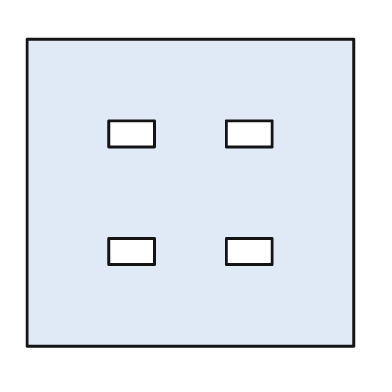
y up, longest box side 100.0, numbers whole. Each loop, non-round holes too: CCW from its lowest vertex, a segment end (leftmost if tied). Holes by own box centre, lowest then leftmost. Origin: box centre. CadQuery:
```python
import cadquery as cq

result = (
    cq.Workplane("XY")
    .moveTo(-50.0, -47.0)
    .lineTo(50.0, -47.0)
    .lineTo(50.0, 47.0)
    .lineTo(-50.0, 47.0)
    .close()
    .moveTo(-25.0, -22.0)
    .lineTo(-11.0, -22.0)
    .lineTo(-11.0, -14.0)
    .lineTo(-25.0, -14.0)
    .close()
    .moveTo(11.0, -22.0)
    .lineTo(25.0, -22.0)
    .lineTo(25.0, -14.0)
    .lineTo(11.0, -14.0)
    .close()
    .moveTo(-25.0, 14.0)
    .lineTo(-11.0, 14.0)
    .lineTo(-11.0, 22.0)
    .lineTo(-25.0, 22.0)
    .close()
    .moveTo(11.0, 14.0)
    .lineTo(25.0, 14.0)
    .lineTo(25.0, 22.0)
    .lineTo(11.0, 22.0)
    .close()
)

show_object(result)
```